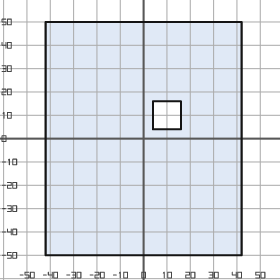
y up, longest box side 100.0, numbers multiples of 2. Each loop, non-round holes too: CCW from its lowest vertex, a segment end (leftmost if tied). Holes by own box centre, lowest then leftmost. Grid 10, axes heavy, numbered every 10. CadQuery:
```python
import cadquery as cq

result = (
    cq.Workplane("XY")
    .moveTo(-42.0, -50.0)
    .lineTo(42.0, -50.0)
    .lineTo(42.0, 50.0)
    .lineTo(-42.0, 50.0)
    .close()
    .moveTo(4.0, 4.0)
    .lineTo(16.0, 4.0)
    .lineTo(16.0, 16.0)
    .lineTo(4.0, 16.0)
    .close()
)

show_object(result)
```